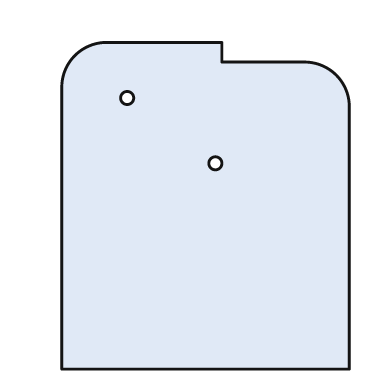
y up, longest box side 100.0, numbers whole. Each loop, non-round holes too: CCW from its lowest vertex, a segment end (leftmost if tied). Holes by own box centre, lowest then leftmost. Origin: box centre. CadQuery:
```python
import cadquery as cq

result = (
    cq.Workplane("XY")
    .moveTo(-44.0, -50.0)
    .lineTo(44.0, -50.0)
    .lineTo(44.0, 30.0)
    .threePointArc((40.0, 40.0), (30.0, 44.0))
    .lineTo(5.0, 44.0)
    .lineTo(5.0, 50.0)
    .lineTo(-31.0, 50.0)
    .threePointArc((-40.0, 46.0), (-44.0, 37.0))
    .close()
    .moveTo(3.0, 13.0)
    .circle(2.0)
    .moveTo(-24.0, 33.0)
    .circle(2.0)
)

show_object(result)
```